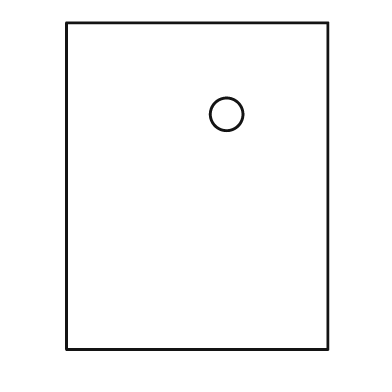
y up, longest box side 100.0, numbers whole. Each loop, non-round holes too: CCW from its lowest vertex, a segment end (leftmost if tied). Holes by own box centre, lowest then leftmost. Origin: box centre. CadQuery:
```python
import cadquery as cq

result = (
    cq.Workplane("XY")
    .moveTo(-40.0, -50.0)
    .lineTo(40.0, -50.0)
    .lineTo(40.0, 50.0)
    .lineTo(-40.0, 50.0)
    .close()
    .moveTo(9.0, 22.0)
    .circle(5.0)
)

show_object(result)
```